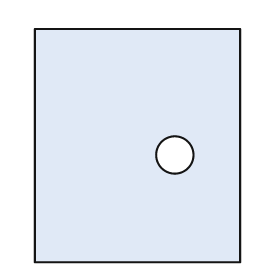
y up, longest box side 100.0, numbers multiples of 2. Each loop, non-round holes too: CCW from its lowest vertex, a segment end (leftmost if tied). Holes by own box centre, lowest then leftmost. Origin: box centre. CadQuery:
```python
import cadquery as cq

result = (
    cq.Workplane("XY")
    .moveTo(-44.0, -50.0)
    .lineTo(44.0, -50.0)
    .lineTo(44.0, 50.0)
    .lineTo(-44.0, 50.0)
    .close()
    .moveTo(16.0, -4.0)
    .circle(8.0)
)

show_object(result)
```